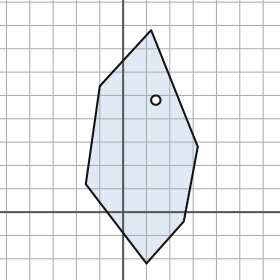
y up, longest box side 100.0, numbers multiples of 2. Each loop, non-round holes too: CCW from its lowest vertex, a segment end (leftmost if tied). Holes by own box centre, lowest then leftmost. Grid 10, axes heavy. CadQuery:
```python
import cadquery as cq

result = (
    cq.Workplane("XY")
    .moveTo(10.0, -22.0)
    .lineTo(26.0, -4.0)
    .lineTo(32.0, 28.0)
    .lineTo(12.0, 78.0)
    .lineTo(-10.0, 54.0)
    .lineTo(-16.0, 12.0)
    .close()
    .moveTo(14.0, 48.0)
    .circle(2.0)
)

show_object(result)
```